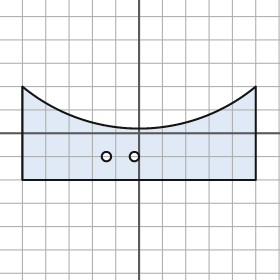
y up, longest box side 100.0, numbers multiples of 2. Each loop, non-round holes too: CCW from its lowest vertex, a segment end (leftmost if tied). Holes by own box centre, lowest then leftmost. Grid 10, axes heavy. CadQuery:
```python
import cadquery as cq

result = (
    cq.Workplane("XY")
    .moveTo(-50.0, -20.0)
    .lineTo(50.0, -20.0)
    .lineTo(50.0, 20.0)
    .threePointArc((0.0, 2.0), (-50.0, 20.0))
    .close()
    .moveTo(-14.0, -10.0)
    .circle(2.0)
    .moveTo(-2.0, -10.0)
    .circle(2.0)
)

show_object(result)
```